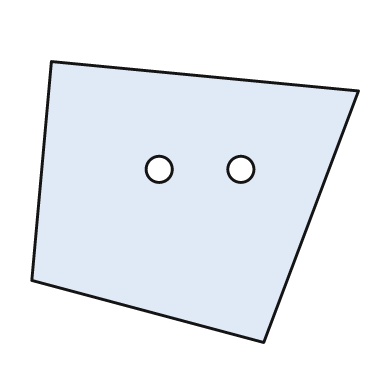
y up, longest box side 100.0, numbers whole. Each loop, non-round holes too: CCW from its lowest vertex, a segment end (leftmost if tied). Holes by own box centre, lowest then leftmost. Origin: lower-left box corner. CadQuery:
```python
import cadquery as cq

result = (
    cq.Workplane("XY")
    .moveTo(71.0, 0.0)
    .lineTo(100.0, 77.0)
    .lineTo(6.0, 86.0)
    .lineTo(0.0, 19.0)
    .close()
    .moveTo(39.0, 53.0)
    .circle(4.0)
    .moveTo(64.0, 53.0)
    .circle(4.0)
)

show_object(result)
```